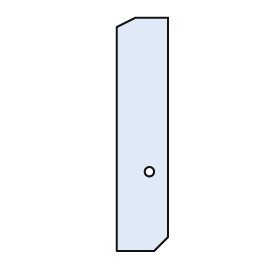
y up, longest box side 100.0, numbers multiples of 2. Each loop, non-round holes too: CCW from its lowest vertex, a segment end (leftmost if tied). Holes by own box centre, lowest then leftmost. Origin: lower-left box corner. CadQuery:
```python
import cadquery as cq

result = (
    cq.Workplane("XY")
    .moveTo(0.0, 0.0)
    .lineTo(16.0, 0.0)
    .lineTo(22.0, 6.0)
    .lineTo(22.0, 100.0)
    .lineTo(8.0, 100.0)
    .lineTo(0.0, 96.0)
    .close()
    .moveTo(14.0, 34.0)
    .circle(2.0)
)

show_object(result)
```